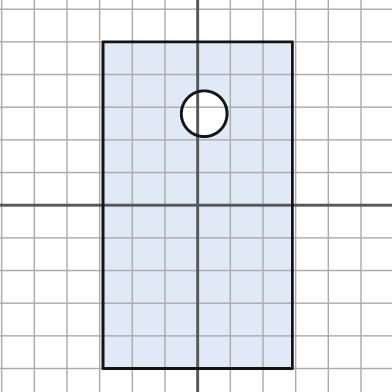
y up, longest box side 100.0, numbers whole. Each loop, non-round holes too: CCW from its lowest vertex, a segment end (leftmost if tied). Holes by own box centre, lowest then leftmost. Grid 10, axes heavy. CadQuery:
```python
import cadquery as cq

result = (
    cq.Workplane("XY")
    .moveTo(-29.0, -50.0)
    .lineTo(29.0, -50.0)
    .lineTo(29.0, 50.0)
    .lineTo(-29.0, 50.0)
    .close()
    .moveTo(2.0, 28.0)
    .circle(7.0)
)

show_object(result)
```